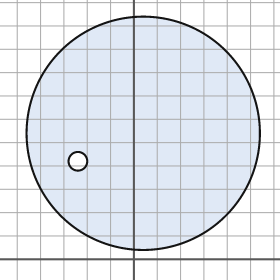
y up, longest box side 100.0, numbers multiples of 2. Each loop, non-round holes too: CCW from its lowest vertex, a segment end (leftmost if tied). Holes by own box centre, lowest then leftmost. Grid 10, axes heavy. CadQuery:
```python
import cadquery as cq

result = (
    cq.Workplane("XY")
    .moveTo(4.0, 54.0)
    .circle(50.0)
    .moveTo(-24.0, 42.0)
    .circle(4.0)
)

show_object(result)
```